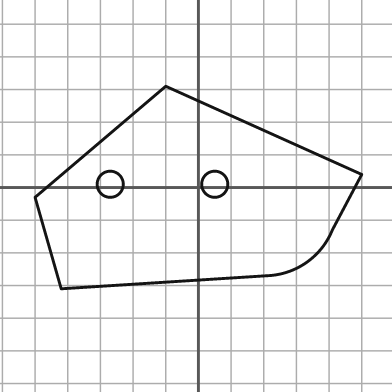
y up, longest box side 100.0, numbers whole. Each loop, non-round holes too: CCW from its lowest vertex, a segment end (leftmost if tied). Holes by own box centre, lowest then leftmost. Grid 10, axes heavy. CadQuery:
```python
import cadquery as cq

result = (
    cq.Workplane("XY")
    .moveTo(-42.0, -31.0)
    .lineTo(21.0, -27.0)
    .threePointArc((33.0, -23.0), (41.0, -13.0))
    .lineTo(50.0, 4.0)
    .lineTo(-10.0, 31.0)
    .lineTo(-50.0, -3.0)
    .close()
    .moveTo(-27.0, 1.0)
    .circle(4.0)
    .moveTo(5.0, 1.0)
    .circle(4.0)
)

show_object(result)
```